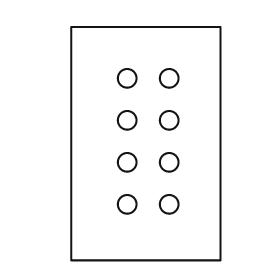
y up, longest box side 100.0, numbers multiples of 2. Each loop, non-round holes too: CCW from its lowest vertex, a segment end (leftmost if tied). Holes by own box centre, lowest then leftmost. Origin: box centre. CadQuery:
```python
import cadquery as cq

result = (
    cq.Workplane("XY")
    .moveTo(-32.0, -50.0)
    .lineTo(32.0, -50.0)
    .lineTo(32.0, 50.0)
    .lineTo(-32.0, 50.0)
    .close()
    .moveTo(-8.0, -26.0)
    .circle(4.0)
    .moveTo(10.0, -26.0)
    .circle(4.0)
    .moveTo(-8.0, -8.0)
    .circle(4.0)
    .moveTo(10.0, -8.0)
    .circle(4.0)
    .moveTo(-8.0, 10.0)
    .circle(4.0)
    .moveTo(10.0, 10.0)
    .circle(4.0)
    .moveTo(-8.0, 28.0)
    .circle(4.0)
    .moveTo(10.0, 28.0)
    .circle(4.0)
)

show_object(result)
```